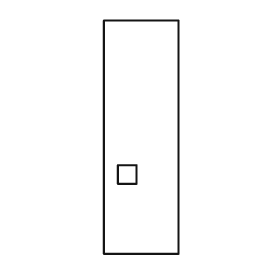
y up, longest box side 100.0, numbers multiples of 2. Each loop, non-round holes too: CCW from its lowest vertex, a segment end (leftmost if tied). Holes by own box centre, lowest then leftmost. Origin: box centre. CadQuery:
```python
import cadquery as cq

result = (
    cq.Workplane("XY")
    .moveTo(-16.0, -50.0)
    .lineTo(16.0, -50.0)
    .lineTo(16.0, 50.0)
    .lineTo(-16.0, 50.0)
    .close()
    .moveTo(-10.0, -20.0)
    .lineTo(-2.0, -20.0)
    .lineTo(-2.0, -12.0)
    .lineTo(-10.0, -12.0)
    .close()
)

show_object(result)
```